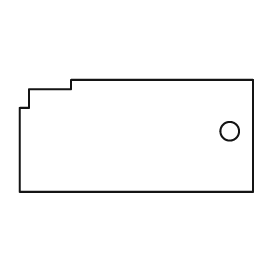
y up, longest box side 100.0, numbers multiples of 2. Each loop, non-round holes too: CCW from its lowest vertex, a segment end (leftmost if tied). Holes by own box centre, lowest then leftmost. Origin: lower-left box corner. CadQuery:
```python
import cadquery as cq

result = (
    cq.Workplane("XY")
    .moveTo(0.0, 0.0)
    .lineTo(100.0, 0.0)
    .lineTo(100.0, 48.0)
    .lineTo(22.0, 48.0)
    .lineTo(22.0, 44.0)
    .lineTo(4.0, 44.0)
    .lineTo(4.0, 36.0)
    .lineTo(0.0, 36.0)
    .close()
    .moveTo(90.0, 26.0)
    .circle(4.0)
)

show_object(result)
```